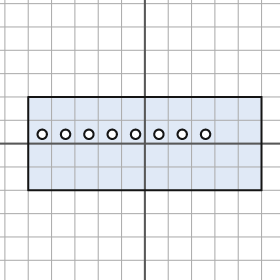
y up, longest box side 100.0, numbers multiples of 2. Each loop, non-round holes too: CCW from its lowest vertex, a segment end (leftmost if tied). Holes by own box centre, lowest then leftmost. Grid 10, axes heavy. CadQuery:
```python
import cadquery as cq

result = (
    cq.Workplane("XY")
    .moveTo(-50.0, -20.0)
    .lineTo(50.0, -20.0)
    .lineTo(50.0, 20.0)
    .lineTo(-50.0, 20.0)
    .close()
    .moveTo(-44.0, 4.0)
    .circle(2.0)
    .moveTo(-34.0, 4.0)
    .circle(2.0)
    .moveTo(-24.0, 4.0)
    .circle(2.0)
    .moveTo(-14.0, 4.0)
    .circle(2.0)
    .moveTo(-4.0, 4.0)
    .circle(2.0)
    .moveTo(6.0, 4.0)
    .circle(2.0)
    .moveTo(16.0, 4.0)
    .circle(2.0)
    .moveTo(26.0, 4.0)
    .circle(2.0)
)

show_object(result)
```